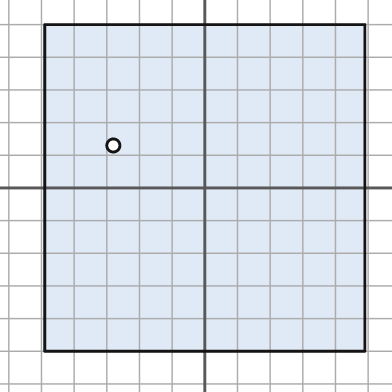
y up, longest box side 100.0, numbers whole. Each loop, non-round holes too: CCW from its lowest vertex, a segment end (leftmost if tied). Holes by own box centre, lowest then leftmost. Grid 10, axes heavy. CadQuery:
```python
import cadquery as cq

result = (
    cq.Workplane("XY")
    .moveTo(-49.0, -50.0)
    .lineTo(49.0, -50.0)
    .lineTo(49.0, 50.0)
    .lineTo(-49.0, 50.0)
    .close()
    .moveTo(-28.0, 13.0)
    .circle(2.0)
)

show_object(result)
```